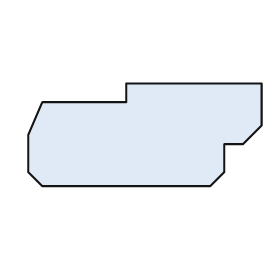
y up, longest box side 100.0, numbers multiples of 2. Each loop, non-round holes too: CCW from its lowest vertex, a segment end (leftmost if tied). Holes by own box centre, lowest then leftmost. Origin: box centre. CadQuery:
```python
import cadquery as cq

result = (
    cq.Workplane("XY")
    .moveTo(-44.0, -22.0)
    .lineTo(28.0, -22.0)
    .lineTo(34.0, -16.0)
    .lineTo(34.0, -4.0)
    .lineTo(42.0, -4.0)
    .lineTo(50.0, 4.0)
    .lineTo(50.0, 22.0)
    .lineTo(-8.0, 22.0)
    .lineTo(-8.0, 14.0)
    .lineTo(-44.0, 14.0)
    .lineTo(-50.0, 0.0)
    .lineTo(-50.0, -16.0)
    .close()
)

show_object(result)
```